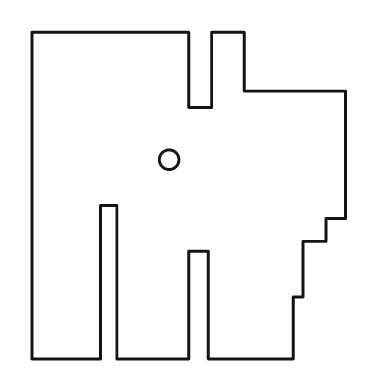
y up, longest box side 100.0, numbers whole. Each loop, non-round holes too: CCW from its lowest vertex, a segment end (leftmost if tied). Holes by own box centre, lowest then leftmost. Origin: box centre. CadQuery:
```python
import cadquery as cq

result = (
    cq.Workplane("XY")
    .moveTo(-48.0, -50.0)
    .lineTo(-27.0, -50.0)
    .lineTo(-27.0, -3.0)
    .lineTo(-22.0, -3.0)
    .lineTo(-22.0, -50.0)
    .lineTo(0.0, -50.0)
    .lineTo(0.0, -17.0)
    .lineTo(6.0, -17.0)
    .lineTo(6.0, -50.0)
    .lineTo(32.0, -50.0)
    .lineTo(32.0, -31.0)
    .lineTo(35.0, -31.0)
    .lineTo(35.0, -14.0)
    .lineTo(42.0, -14.0)
    .lineTo(42.0, -7.0)
    .lineTo(48.0, -7.0)
    .lineTo(48.0, 32.0)
    .lineTo(17.0, 32.0)
    .lineTo(17.0, 50.0)
    .lineTo(7.0, 50.0)
    .lineTo(7.0, 27.0)
    .lineTo(0.0, 27.0)
    .lineTo(0.0, 50.0)
    .lineTo(-48.0, 50.0)
    .close()
    .moveTo(-6.0, 11.0)
    .circle(3.0)
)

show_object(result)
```